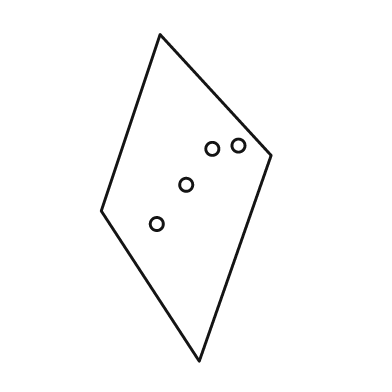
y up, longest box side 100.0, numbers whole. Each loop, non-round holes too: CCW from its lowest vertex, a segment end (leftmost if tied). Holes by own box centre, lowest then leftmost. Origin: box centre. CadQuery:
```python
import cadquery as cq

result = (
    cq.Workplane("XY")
    .moveTo(4.0, -50.0)
    .lineTo(26.0, 13.0)
    .lineTo(-8.0, 50.0)
    .lineTo(-26.0, -4.0)
    .close()
    .moveTo(-9.0, -8.0)
    .circle(2.0)
    .moveTo(0.0, 4.0)
    .circle(2.0)
    .moveTo(8.0, 15.0)
    .circle(2.0)
    .moveTo(16.0, 16.0)
    .circle(2.0)
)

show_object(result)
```